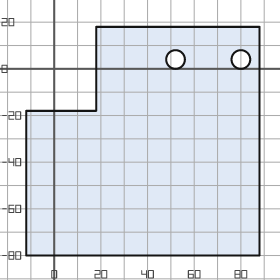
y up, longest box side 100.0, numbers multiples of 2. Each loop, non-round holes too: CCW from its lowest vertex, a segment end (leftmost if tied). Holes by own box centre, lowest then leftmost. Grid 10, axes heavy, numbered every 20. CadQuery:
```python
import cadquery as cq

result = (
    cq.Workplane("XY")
    .moveTo(-12.0, -80.0)
    .lineTo(88.0, -80.0)
    .lineTo(88.0, 18.0)
    .lineTo(18.0, 18.0)
    .lineTo(18.0, -18.0)
    .lineTo(-12.0, -18.0)
    .close()
    .moveTo(52.0, 4.0)
    .circle(4.0)
    .moveTo(80.0, 4.0)
    .circle(4.0)
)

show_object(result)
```